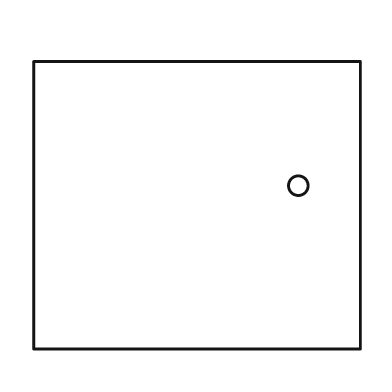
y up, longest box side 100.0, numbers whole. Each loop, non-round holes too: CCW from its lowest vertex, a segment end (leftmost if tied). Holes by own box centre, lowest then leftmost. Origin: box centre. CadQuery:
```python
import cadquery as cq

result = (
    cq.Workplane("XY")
    .moveTo(-50.0, -44.0)
    .lineTo(50.0, -44.0)
    .lineTo(50.0, 44.0)
    .lineTo(-50.0, 44.0)
    .close()
    .moveTo(31.0, 6.0)
    .circle(3.0)
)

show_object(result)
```